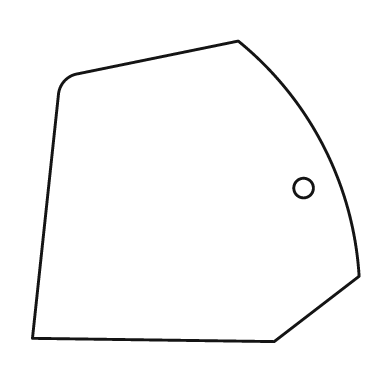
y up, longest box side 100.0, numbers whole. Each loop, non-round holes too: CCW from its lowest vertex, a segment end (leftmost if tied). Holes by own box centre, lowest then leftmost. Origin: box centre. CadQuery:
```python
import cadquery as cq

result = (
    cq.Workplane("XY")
    .moveTo(24.0, -46.0)
    .lineTo(50.0, -26.0)
    .threePointArc((39.0, 14.0), (13.0, 46.0))
    .lineTo(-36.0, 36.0)
    .threePointArc((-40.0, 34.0), (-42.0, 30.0))
    .lineTo(-50.0, -45.0)
    .close()
    .moveTo(33.0, 1.0)
    .circle(3.0)
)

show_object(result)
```